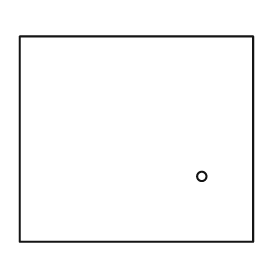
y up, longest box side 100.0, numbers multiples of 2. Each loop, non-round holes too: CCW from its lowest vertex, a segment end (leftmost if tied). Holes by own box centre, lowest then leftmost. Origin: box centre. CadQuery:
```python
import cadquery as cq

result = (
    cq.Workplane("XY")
    .moveTo(-50.0, -44.0)
    .lineTo(50.0, -44.0)
    .lineTo(50.0, 44.0)
    .lineTo(-50.0, 44.0)
    .close()
    .moveTo(28.0, -16.0)
    .circle(2.0)
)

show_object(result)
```